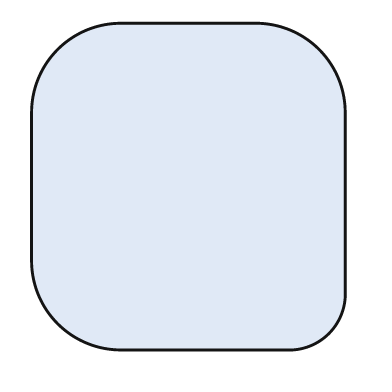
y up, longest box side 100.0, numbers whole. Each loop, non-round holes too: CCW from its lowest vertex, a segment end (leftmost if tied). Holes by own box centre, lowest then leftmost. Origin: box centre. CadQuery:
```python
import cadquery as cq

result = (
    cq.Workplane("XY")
    .moveTo(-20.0, -50.0)
    .lineTo(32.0, -50.0)
    .threePointArc((43.0, -45.0), (48.0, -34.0))
    .lineTo(48.0, 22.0)
    .threePointArc((40.0, 42.0), (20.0, 50.0))
    .lineTo(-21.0, 50.0)
    .threePointArc((-40.0, 42.0), (-48.0, 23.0))
    .lineTo(-48.0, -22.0)
    .threePointArc((-40.0, -42.0), (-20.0, -50.0))
    .close()
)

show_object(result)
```